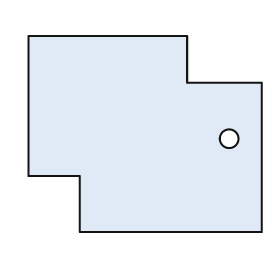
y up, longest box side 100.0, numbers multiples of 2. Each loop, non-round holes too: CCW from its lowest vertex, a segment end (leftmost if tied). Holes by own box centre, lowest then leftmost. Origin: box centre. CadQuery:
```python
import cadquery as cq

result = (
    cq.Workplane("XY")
    .moveTo(-28.0, -42.0)
    .lineTo(50.0, -42.0)
    .lineTo(50.0, 22.0)
    .lineTo(18.0, 22.0)
    .lineTo(18.0, 42.0)
    .lineTo(-50.0, 42.0)
    .lineTo(-50.0, -18.0)
    .lineTo(-28.0, -18.0)
    .close()
    .moveTo(36.0, -2.0)
    .circle(4.0)
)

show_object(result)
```